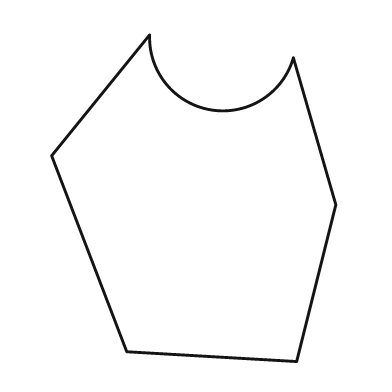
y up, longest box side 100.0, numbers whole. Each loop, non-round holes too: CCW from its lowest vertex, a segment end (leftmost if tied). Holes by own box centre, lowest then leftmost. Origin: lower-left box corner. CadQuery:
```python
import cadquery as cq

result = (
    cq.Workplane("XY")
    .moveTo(75.0, 0.0)
    .lineTo(87.0, 48.0)
    .lineTo(74.0, 93.0)
    .threePointArc((49.0, 77.0), (30.0, 100.0))
    .lineTo(0.0, 63.0)
    .lineTo(23.0, 3.0)
    .close()
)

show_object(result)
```